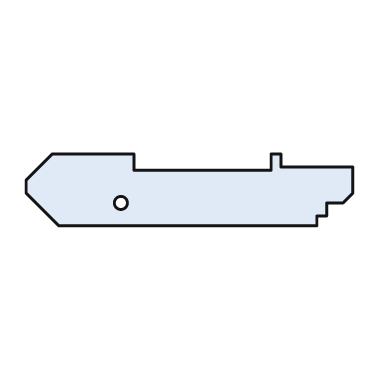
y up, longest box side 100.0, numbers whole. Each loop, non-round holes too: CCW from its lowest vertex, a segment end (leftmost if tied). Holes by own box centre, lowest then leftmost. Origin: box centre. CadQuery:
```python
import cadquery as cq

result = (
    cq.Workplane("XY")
    .moveTo(-40.0, -11.0)
    .lineTo(39.0, -11.0)
    .lineTo(39.0, -8.0)
    .lineTo(42.0, -8.0)
    .lineTo(42.0, -4.0)
    .lineTo(47.0, -4.0)
    .lineTo(50.0, -1.0)
    .lineTo(50.0, 7.0)
    .lineTo(28.0, 7.0)
    .lineTo(28.0, 11.0)
    .lineTo(25.0, 11.0)
    .lineTo(25.0, 6.0)
    .lineTo(-17.0, 6.0)
    .lineTo(-17.0, 11.0)
    .lineTo(-42.0, 11.0)
    .lineTo(-50.0, 3.0)
    .lineTo(-50.0, -1.0)
    .close()
    .moveTo(-21.0, -4.0)
    .circle(2.0)
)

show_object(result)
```